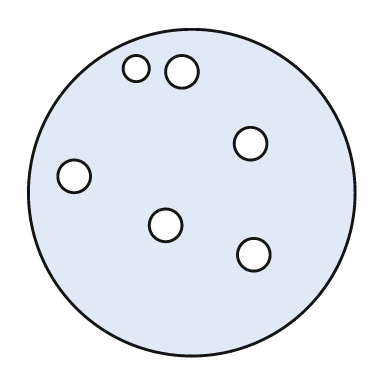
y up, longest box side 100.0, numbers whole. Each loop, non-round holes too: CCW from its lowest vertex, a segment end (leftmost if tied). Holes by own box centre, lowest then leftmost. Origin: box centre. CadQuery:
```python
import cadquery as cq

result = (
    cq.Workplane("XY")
    .moveTo(0.0, 0.0)
    .circle(50.0)
    .moveTo(19.0, -19.0)
    .circle(5.0)
    .moveTo(-8.0, -10.0)
    .circle(5.0)
    .moveTo(-36.0, 5.0)
    .circle(5.0)
    .moveTo(18.0, 15.0)
    .circle(5.0)
    .moveTo(-3.0, 37.0)
    .circle(5.0)
    .moveTo(-17.0, 38.0)
    .circle(4.0)
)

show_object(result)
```